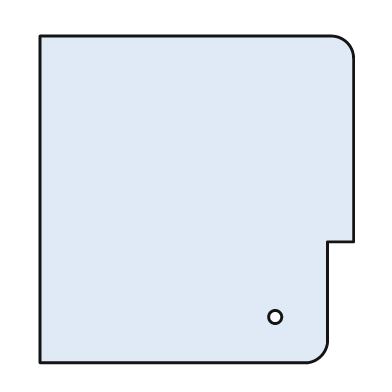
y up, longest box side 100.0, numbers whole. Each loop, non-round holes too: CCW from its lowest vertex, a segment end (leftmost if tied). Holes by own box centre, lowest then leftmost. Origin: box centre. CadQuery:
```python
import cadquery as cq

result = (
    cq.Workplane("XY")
    .moveTo(-48.0, -50.0)
    .lineTo(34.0, -50.0)
    .threePointArc((38.0, -48.0), (40.0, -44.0))
    .lineTo(40.0, -13.0)
    .lineTo(48.0, -13.0)
    .lineTo(48.0, 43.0)
    .threePointArc((46.0, 48.0), (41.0, 50.0))
    .lineTo(-48.0, 50.0)
    .close()
    .moveTo(24.0, -36.0)
    .circle(2.0)
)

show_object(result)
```